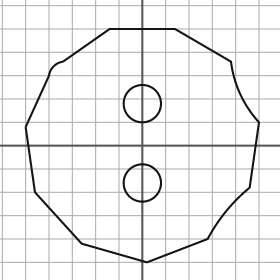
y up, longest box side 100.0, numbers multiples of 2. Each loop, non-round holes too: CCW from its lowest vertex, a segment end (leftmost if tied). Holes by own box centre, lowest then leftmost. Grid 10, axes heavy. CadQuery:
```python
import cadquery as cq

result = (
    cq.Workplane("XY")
    .moveTo(2.0, -50.0)
    .lineTo(28.0, -40.0)
    .threePointArc((36.0, -28.0), (46.0, -18.0))
    .lineTo(50.0, 10.0)
    .threePointArc((42.0, 22.0), (38.0, 36.0))
    .lineTo(14.0, 50.0)
    .lineTo(-14.0, 50.0)
    .lineTo(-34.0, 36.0)
    .threePointArc((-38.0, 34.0), (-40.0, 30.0))
    .lineTo(-50.0, 8.0)
    .lineTo(-46.0, -20.0)
    .lineTo(-26.0, -42.0)
    .close()
    .moveTo(0.0, -16.0)
    .circle(8.0)
    .moveTo(0.0, 18.0)
    .circle(8.0)
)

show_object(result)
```